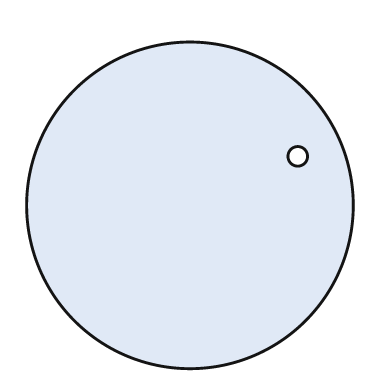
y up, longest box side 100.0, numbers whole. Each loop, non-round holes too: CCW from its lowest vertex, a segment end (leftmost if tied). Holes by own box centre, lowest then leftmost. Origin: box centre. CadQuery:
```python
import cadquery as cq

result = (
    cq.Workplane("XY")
    .moveTo(0.0, 0.0)
    .circle(50.0)
    .moveTo(33.0, 15.0)
    .circle(3.0)
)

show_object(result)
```